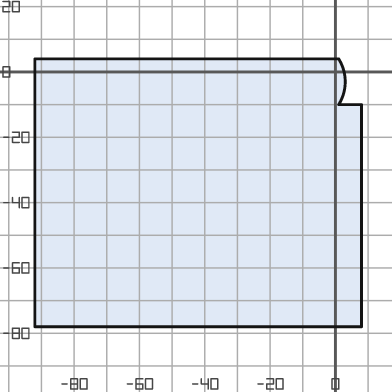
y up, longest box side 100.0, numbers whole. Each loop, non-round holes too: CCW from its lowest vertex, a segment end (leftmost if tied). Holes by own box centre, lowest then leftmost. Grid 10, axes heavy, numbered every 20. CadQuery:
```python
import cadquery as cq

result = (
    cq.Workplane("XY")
    .moveTo(-92.0, -78.0)
    .lineTo(8.0, -78.0)
    .lineTo(8.0, -10.0)
    .lineTo(1.0, -10.0)
    .threePointArc((3.0, -3.0), (1.0, 4.0))
    .lineTo(-92.0, 4.0)
    .close()
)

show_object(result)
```